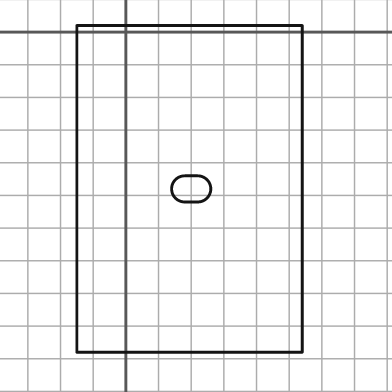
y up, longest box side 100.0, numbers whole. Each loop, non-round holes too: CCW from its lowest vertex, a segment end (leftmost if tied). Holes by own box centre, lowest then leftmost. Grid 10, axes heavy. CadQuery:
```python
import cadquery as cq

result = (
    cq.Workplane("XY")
    .moveTo(-15.0, -98.0)
    .lineTo(54.0, -98.0)
    .lineTo(54.0, 2.0)
    .lineTo(-15.0, 2.0)
    .close()
    .moveTo(18.0, -52.0)
    .lineTo(22.0, -52.0)
    .threePointArc((26.0, -48.0), (22.0, -44.0))
    .lineTo(18.0, -44.0)
    .threePointArc((14.0, -48.0), (18.0, -52.0))
    .close()
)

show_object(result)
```